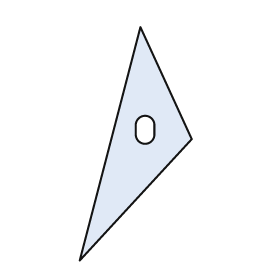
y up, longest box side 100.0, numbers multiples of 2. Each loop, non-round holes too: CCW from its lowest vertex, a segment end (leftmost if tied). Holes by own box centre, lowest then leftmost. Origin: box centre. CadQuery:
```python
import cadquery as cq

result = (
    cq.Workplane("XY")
    .moveTo(-24.0, -50.0)
    .lineTo(24.0, 2.0)
    .lineTo(2.0, 50.0)
    .close()
    .moveTo(0.0, 4.0)
    .threePointArc((4.0, 0.0), (8.0, 4.0))
    .lineTo(8.0, 8.0)
    .threePointArc((4.0, 12.0), (0.0, 8.0))
    .close()
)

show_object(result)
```